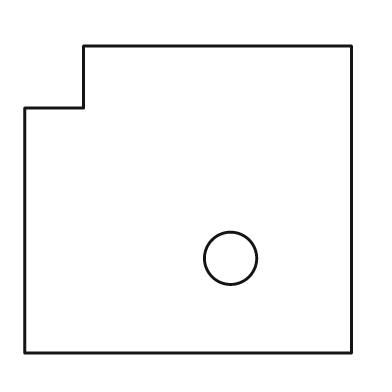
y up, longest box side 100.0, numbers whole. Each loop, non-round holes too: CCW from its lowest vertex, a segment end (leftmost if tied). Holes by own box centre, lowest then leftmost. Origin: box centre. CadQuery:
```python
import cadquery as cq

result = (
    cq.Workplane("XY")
    .moveTo(-50.0, -47.0)
    .lineTo(50.0, -47.0)
    .lineTo(50.0, 47.0)
    .lineTo(-32.0, 47.0)
    .lineTo(-32.0, 28.0)
    .lineTo(-50.0, 28.0)
    .close()
    .moveTo(13.0, -18.0)
    .circle(8.0)
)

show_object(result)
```